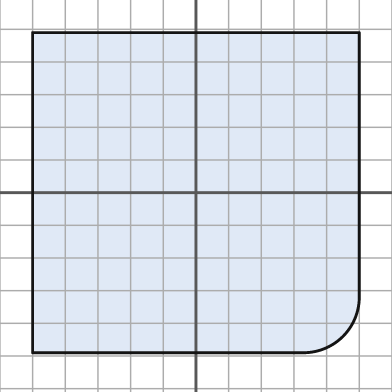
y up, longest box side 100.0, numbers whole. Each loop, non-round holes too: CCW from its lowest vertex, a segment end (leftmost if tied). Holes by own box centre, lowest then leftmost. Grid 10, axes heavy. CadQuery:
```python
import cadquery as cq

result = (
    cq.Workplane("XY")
    .moveTo(-50.0, -49.0)
    .lineTo(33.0, -49.0)
    .threePointArc((45.0, -44.0), (50.0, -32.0))
    .lineTo(50.0, 49.0)
    .lineTo(-50.0, 49.0)
    .close()
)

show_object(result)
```